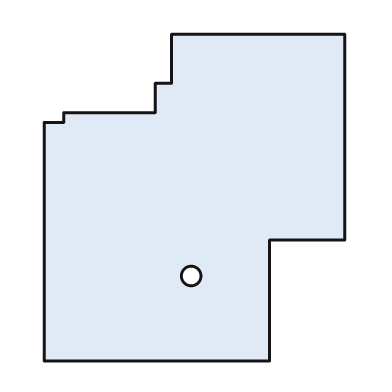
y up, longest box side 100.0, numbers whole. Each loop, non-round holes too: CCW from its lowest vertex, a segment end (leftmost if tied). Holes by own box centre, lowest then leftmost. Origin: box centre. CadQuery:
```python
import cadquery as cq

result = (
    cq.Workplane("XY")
    .moveTo(-46.0, -50.0)
    .lineTo(23.0, -50.0)
    .lineTo(23.0, -13.0)
    .lineTo(46.0, -13.0)
    .lineTo(46.0, 50.0)
    .lineTo(-7.0, 50.0)
    .lineTo(-7.0, 35.0)
    .lineTo(-12.0, 35.0)
    .lineTo(-12.0, 26.0)
    .lineTo(-40.0, 26.0)
    .lineTo(-40.0, 23.0)
    .lineTo(-46.0, 23.0)
    .close()
    .moveTo(-1.0, -24.0)
    .circle(3.0)
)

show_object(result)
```